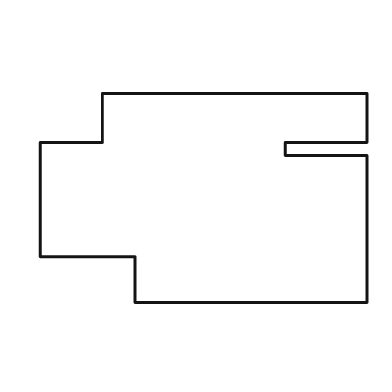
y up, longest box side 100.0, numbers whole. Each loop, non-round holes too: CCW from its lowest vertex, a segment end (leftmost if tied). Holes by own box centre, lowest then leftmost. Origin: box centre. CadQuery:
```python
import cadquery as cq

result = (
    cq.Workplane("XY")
    .moveTo(-21.0, -32.0)
    .lineTo(50.0, -32.0)
    .lineTo(50.0, 13.0)
    .lineTo(25.0, 13.0)
    .lineTo(25.0, 17.0)
    .lineTo(50.0, 17.0)
    .lineTo(50.0, 32.0)
    .lineTo(-31.0, 32.0)
    .lineTo(-31.0, 17.0)
    .lineTo(-50.0, 17.0)
    .lineTo(-50.0, -18.0)
    .lineTo(-21.0, -18.0)
    .close()
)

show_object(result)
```